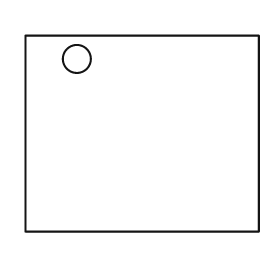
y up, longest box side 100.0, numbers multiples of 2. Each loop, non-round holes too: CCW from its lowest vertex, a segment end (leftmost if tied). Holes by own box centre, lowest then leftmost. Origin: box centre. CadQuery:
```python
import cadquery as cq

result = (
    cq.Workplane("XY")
    .moveTo(-50.0, -42.0)
    .lineTo(50.0, -42.0)
    .lineTo(50.0, 42.0)
    .lineTo(-50.0, 42.0)
    .close()
    .moveTo(-28.0, 32.0)
    .circle(6.0)
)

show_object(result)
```